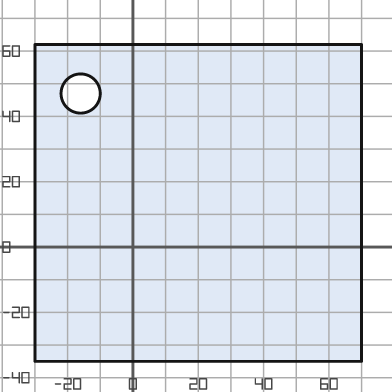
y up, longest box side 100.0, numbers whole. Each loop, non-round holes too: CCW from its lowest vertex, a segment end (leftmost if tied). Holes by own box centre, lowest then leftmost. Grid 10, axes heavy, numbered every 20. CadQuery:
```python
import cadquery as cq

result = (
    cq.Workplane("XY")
    .moveTo(-30.0, -35.0)
    .lineTo(70.0, -35.0)
    .lineTo(70.0, 62.0)
    .lineTo(-30.0, 62.0)
    .close()
    .moveTo(-16.0, 47.0)
    .circle(6.0)
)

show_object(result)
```